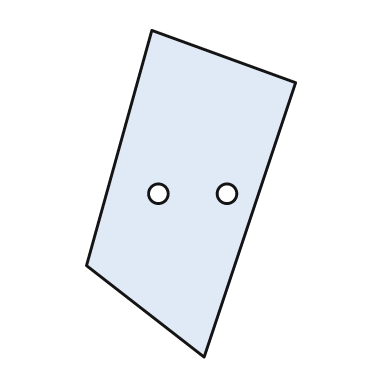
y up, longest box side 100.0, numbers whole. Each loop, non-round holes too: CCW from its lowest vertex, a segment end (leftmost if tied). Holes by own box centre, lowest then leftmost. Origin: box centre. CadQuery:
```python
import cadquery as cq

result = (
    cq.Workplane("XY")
    .moveTo(4.0, -50.0)
    .lineTo(32.0, 34.0)
    .lineTo(-12.0, 50.0)
    .lineTo(-32.0, -22.0)
    .close()
    .moveTo(-10.0, 0.0)
    .circle(3.0)
    .moveTo(11.0, 0.0)
    .circle(3.0)
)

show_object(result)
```